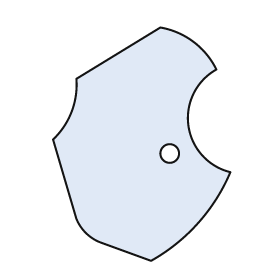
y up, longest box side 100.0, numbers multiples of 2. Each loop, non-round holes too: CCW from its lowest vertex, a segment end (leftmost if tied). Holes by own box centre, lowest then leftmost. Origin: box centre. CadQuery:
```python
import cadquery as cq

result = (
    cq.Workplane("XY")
    .moveTo(4.0, -50.0)
    .threePointArc((24.0, -34.0), (38.0, -12.0))
    .threePointArc((20.0, 8.0), (32.0, 32.0))
    .threePointArc((22.0, 44.0), (8.0, 50.0))
    .lineTo(-28.0, 28.0)
    .threePointArc((-30.0, 14.0), (-38.0, 2.0))
    .lineTo(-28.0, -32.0)
    .threePointArc((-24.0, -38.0), (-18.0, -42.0))
    .close()
    .moveTo(12.0, -4.0)
    .circle(4.0)
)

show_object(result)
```